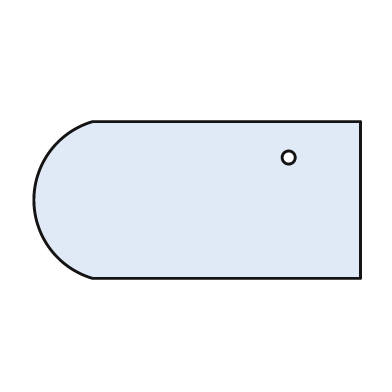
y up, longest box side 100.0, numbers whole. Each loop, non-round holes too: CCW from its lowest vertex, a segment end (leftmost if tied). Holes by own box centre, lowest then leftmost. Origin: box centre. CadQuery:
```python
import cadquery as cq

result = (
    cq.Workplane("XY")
    .moveTo(-32.0, -24.0)
    .lineTo(50.0, -24.0)
    .lineTo(50.0, 24.0)
    .lineTo(-32.0, 24.0)
    .threePointArc((-50.0, 0.0), (-32.0, -24.0))
    .close()
    .moveTo(28.0, 13.0)
    .circle(2.0)
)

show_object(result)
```